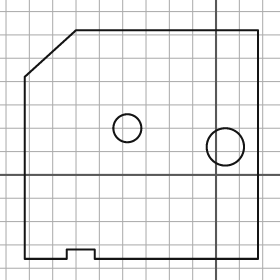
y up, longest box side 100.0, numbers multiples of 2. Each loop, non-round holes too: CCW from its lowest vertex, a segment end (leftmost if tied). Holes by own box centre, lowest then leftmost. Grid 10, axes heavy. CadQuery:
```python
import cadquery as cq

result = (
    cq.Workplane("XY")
    .moveTo(-82.0, -36.0)
    .lineTo(-64.0, -36.0)
    .lineTo(-64.0, -32.0)
    .lineTo(-52.0, -32.0)
    .lineTo(-52.0, -36.0)
    .lineTo(18.0, -36.0)
    .lineTo(18.0, 62.0)
    .lineTo(-60.0, 62.0)
    .lineTo(-82.0, 42.0)
    .close()
    .moveTo(4.0, 12.0)
    .circle(8.0)
    .moveTo(-38.0, 20.0)
    .circle(6.0)
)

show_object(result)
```